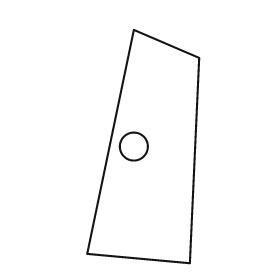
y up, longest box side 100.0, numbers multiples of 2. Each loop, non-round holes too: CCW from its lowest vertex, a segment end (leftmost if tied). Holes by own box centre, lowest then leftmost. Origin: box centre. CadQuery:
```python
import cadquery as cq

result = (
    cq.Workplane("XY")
    .moveTo(20.0, -50.0)
    .lineTo(24.0, 38.0)
    .lineTo(-4.0, 50.0)
    .lineTo(-24.0, -46.0)
    .close()
    .moveTo(-4.0, 0.0)
    .circle(6.0)
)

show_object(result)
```